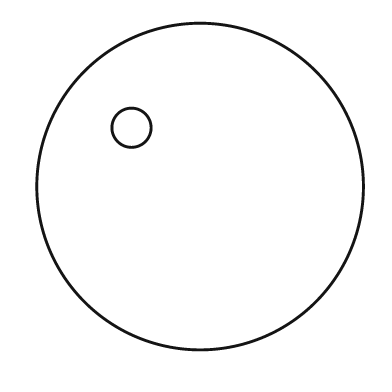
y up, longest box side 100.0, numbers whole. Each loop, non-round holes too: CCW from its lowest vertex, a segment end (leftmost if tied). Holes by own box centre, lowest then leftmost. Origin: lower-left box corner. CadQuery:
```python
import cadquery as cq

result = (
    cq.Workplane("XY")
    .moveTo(50.0, 50.0)
    .circle(50.0)
    .moveTo(29.0, 68.0)
    .circle(6.0)
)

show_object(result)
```